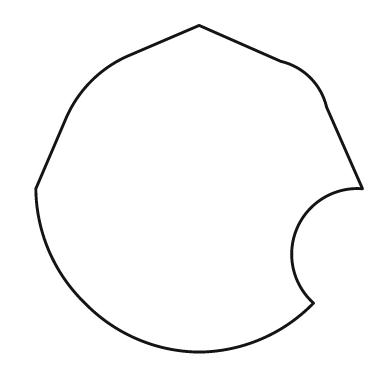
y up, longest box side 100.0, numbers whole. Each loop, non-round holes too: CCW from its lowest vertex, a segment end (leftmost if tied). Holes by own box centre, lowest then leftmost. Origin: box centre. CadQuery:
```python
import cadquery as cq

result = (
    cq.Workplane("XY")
    .moveTo(0.0, -50.0)
    .threePointArc((19.0, -46.0), (35.0, -35.0))
    .threePointArc((30.0, -12.0), (50.0, 0.0))
    .lineTo(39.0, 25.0)
    .threePointArc((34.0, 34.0), (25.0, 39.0))
    .lineTo(0.0, 50.0)
    .lineTo(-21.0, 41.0)
    .threePointArc((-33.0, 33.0), (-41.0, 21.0))
    .lineTo(-50.0, 0.0)
    .threePointArc((-46.0, -19.0), (-35.0, -35.0))
    .threePointArc((-19.0, -46.0), (0.0, -50.0))
    .close()
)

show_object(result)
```